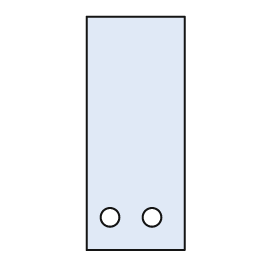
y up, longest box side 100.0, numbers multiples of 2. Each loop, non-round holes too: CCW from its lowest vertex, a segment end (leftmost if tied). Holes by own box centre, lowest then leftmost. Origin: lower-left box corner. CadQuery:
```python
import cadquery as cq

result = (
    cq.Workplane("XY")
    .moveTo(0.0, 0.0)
    .lineTo(42.0, 0.0)
    .lineTo(42.0, 100.0)
    .lineTo(0.0, 100.0)
    .close()
    .moveTo(10.0, 14.0)
    .circle(4.0)
    .moveTo(28.0, 14.0)
    .circle(4.0)
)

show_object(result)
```